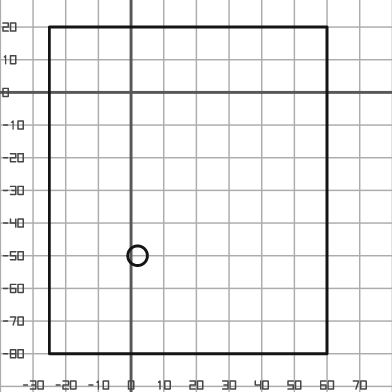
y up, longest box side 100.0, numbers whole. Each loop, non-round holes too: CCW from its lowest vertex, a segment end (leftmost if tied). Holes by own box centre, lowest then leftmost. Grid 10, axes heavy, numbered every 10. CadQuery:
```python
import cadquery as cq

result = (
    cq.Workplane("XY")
    .moveTo(-25.0, -80.0)
    .lineTo(60.0, -80.0)
    .lineTo(60.0, 20.0)
    .lineTo(-25.0, 20.0)
    .close()
    .moveTo(2.0, -50.0)
    .circle(3.0)
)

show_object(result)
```